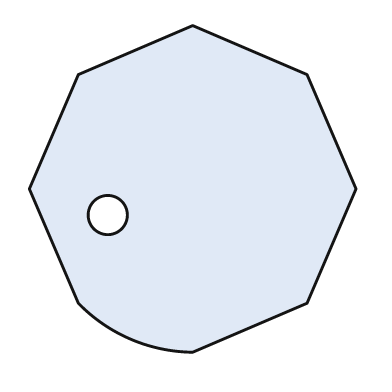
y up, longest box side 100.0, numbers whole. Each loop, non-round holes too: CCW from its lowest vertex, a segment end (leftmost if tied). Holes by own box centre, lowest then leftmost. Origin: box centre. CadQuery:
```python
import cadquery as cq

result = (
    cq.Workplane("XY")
    .moveTo(0.0, -50.0)
    .lineTo(35.0, -35.0)
    .lineTo(50.0, 0.0)
    .lineTo(35.0, 35.0)
    .lineTo(0.0, 50.0)
    .lineTo(-35.0, 35.0)
    .lineTo(-50.0, 0.0)
    .lineTo(-35.0, -35.0)
    .threePointArc((-19.0, -46.0), (0.0, -50.0))
    .close()
    .moveTo(-26.0, -8.0)
    .circle(6.0)
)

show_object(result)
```